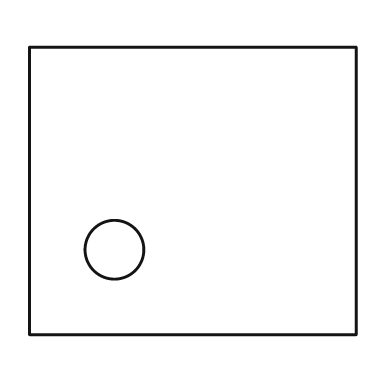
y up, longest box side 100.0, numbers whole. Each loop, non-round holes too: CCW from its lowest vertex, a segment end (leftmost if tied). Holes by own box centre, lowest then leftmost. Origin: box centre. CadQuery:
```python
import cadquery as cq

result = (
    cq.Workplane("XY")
    .moveTo(-50.0, -44.0)
    .lineTo(50.0, -44.0)
    .lineTo(50.0, 44.0)
    .lineTo(-50.0, 44.0)
    .close()
    .moveTo(-24.0, -18.0)
    .circle(9.0)
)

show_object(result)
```